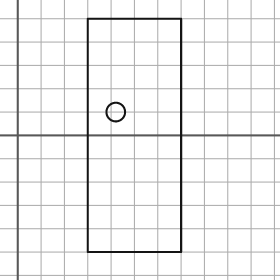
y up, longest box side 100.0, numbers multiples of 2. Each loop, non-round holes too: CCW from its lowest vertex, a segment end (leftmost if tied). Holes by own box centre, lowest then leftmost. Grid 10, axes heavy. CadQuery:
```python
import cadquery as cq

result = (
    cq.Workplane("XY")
    .moveTo(30.0, -50.0)
    .lineTo(70.0, -50.0)
    .lineTo(70.0, 50.0)
    .lineTo(30.0, 50.0)
    .close()
    .moveTo(42.0, 10.0)
    .circle(4.0)
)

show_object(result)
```